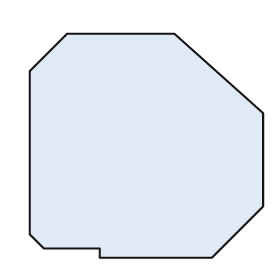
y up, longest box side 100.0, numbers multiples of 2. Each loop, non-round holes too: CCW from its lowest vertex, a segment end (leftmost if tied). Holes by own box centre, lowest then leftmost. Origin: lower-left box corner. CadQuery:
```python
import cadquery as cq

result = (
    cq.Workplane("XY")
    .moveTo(30.0, 0.0)
    .lineTo(78.0, 0.0)
    .lineTo(100.0, 22.0)
    .lineTo(100.0, 62.0)
    .lineTo(62.0, 96.0)
    .lineTo(16.0, 96.0)
    .lineTo(0.0, 80.0)
    .lineTo(0.0, 10.0)
    .lineTo(6.0, 4.0)
    .lineTo(30.0, 4.0)
    .close()
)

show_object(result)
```